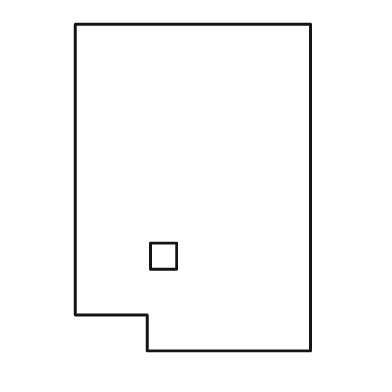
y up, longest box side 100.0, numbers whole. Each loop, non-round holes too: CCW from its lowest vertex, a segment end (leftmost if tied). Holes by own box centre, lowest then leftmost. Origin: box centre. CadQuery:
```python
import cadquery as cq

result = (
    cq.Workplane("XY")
    .moveTo(-14.0, -50.0)
    .lineTo(36.0, -50.0)
    .lineTo(36.0, 50.0)
    .lineTo(-36.0, 50.0)
    .lineTo(-36.0, -39.0)
    .lineTo(-14.0, -39.0)
    .close()
    .moveTo(-13.0, -25.0)
    .lineTo(-5.0, -25.0)
    .lineTo(-5.0, -17.0)
    .lineTo(-13.0, -17.0)
    .close()
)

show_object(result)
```